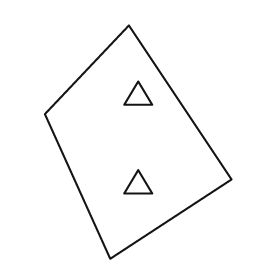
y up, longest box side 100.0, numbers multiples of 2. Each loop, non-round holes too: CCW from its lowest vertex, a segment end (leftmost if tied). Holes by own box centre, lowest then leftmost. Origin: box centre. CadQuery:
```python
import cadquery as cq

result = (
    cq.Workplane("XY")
    .moveTo(-12.0, -50.0)
    .lineTo(40.0, -16.0)
    .lineTo(-4.0, 50.0)
    .lineTo(-40.0, 12.0)
    .close()
    .moveTo(-6.0, -22.0)
    .lineTo(6.0, -22.0)
    .lineTo(0.0, -12.0)
    .close()
    .moveTo(-6.0, 16.0)
    .lineTo(6.0, 16.0)
    .lineTo(0.0, 26.0)
    .close()
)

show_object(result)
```